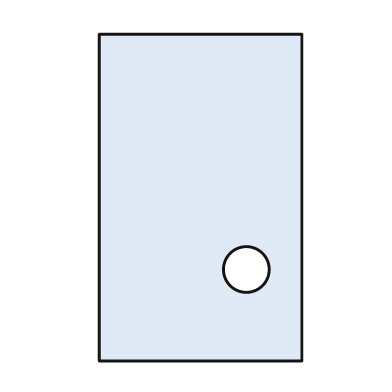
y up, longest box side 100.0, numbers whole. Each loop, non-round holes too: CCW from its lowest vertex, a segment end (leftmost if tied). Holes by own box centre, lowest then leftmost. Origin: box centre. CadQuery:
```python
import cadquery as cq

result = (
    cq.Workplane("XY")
    .moveTo(-31.0, -50.0)
    .lineTo(31.0, -50.0)
    .lineTo(31.0, 50.0)
    .lineTo(-31.0, 50.0)
    .close()
    .moveTo(14.0, -22.0)
    .circle(7.0)
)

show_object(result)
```